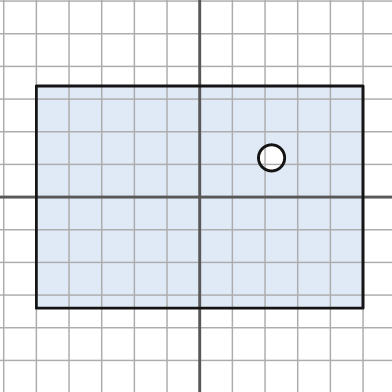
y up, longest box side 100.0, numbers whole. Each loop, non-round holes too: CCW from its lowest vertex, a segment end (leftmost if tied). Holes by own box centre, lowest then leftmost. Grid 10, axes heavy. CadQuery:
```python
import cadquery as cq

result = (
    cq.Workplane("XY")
    .moveTo(-50.0, -34.0)
    .lineTo(50.0, -34.0)
    .lineTo(50.0, 34.0)
    .lineTo(-50.0, 34.0)
    .close()
    .moveTo(22.0, 12.0)
    .circle(4.0)
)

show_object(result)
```